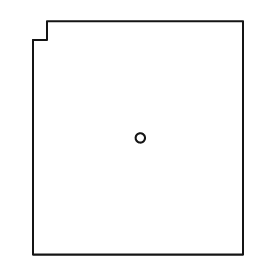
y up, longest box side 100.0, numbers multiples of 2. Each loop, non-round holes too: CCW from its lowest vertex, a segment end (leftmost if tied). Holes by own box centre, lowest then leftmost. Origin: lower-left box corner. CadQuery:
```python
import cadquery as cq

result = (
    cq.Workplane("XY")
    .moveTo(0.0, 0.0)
    .lineTo(90.0, 0.0)
    .lineTo(90.0, 100.0)
    .lineTo(6.0, 100.0)
    .lineTo(6.0, 92.0)
    .lineTo(0.0, 92.0)
    .close()
    .moveTo(46.0, 50.0)
    .circle(2.0)
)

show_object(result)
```